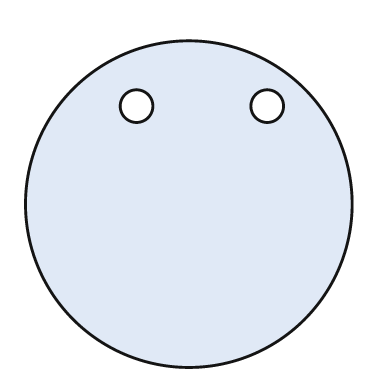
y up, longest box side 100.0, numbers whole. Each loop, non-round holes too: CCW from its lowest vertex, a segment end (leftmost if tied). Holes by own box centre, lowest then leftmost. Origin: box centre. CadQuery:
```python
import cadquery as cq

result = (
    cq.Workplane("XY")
    .moveTo(0.0, 0.0)
    .circle(50.0)
    .moveTo(-16.0, 30.0)
    .circle(5.0)
    .moveTo(24.0, 30.0)
    .circle(5.0)
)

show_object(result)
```